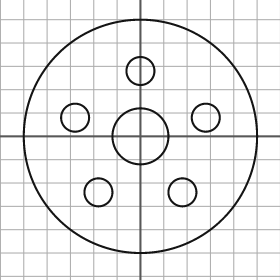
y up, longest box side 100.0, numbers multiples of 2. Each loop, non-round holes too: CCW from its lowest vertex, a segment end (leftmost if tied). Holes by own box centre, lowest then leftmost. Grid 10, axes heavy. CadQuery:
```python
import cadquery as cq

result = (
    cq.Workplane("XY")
    .moveTo(0.0, 0.0)
    .circle(50.0)
    .moveTo(-18.0, -24.0)
    .circle(6.0)
    .moveTo(18.0, -24.0)
    .circle(6.0)
    .moveTo(0.0, 0.0)
    .circle(12.0)
    .moveTo(-28.0, 8.0)
    .circle(6.0)
    .moveTo(28.0, 8.0)
    .circle(6.0)
    .moveTo(0.0, 28.0)
    .circle(6.0)
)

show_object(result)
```